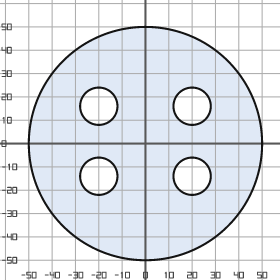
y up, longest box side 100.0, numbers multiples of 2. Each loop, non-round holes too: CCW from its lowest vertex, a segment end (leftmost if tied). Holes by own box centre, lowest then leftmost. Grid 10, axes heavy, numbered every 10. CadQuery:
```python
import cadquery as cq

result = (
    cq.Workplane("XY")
    .moveTo(0.0, 0.0)
    .circle(50.0)
    .moveTo(-20.0, -14.0)
    .circle(8.0)
    .moveTo(20.0, -14.0)
    .circle(8.0)
    .moveTo(-20.0, 16.0)
    .circle(8.0)
    .moveTo(20.0, 16.0)
    .circle(8.0)
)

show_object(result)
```